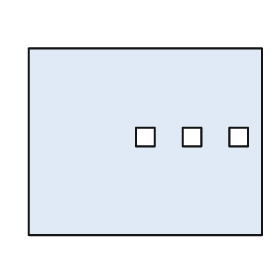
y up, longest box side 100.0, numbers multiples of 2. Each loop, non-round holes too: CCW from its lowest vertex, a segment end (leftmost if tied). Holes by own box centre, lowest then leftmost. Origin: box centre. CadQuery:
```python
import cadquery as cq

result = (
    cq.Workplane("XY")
    .moveTo(-50.0, -40.0)
    .lineTo(50.0, -40.0)
    .lineTo(50.0, 40.0)
    .lineTo(-50.0, 40.0)
    .close()
    .moveTo(-4.0, -2.0)
    .lineTo(4.0, -2.0)
    .lineTo(4.0, 6.0)
    .lineTo(-4.0, 6.0)
    .close()
    .moveTo(16.0, -2.0)
    .lineTo(24.0, -2.0)
    .lineTo(24.0, 6.0)
    .lineTo(16.0, 6.0)
    .close()
    .moveTo(36.0, -2.0)
    .lineTo(44.0, -2.0)
    .lineTo(44.0, 6.0)
    .lineTo(36.0, 6.0)
    .close()
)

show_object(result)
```